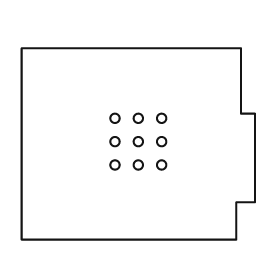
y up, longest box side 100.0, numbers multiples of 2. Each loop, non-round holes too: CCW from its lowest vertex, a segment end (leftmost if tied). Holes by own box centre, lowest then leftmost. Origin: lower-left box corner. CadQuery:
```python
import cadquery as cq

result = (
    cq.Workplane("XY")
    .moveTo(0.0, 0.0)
    .lineTo(92.0, 0.0)
    .lineTo(92.0, 16.0)
    .lineTo(100.0, 16.0)
    .lineTo(100.0, 54.0)
    .lineTo(94.0, 54.0)
    .lineTo(94.0, 82.0)
    .lineTo(0.0, 82.0)
    .close()
    .moveTo(40.0, 32.0)
    .circle(2.0)
    .moveTo(50.0, 32.0)
    .circle(2.0)
    .moveTo(60.0, 32.0)
    .circle(2.0)
    .moveTo(40.0, 42.0)
    .circle(2.0)
    .moveTo(50.0, 42.0)
    .circle(2.0)
    .moveTo(60.0, 42.0)
    .circle(2.0)
    .moveTo(40.0, 52.0)
    .circle(2.0)
    .moveTo(50.0, 52.0)
    .circle(2.0)
    .moveTo(60.0, 52.0)
    .circle(2.0)
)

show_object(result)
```